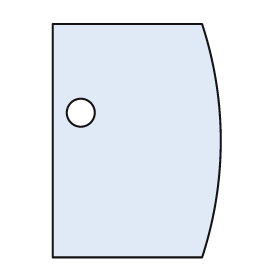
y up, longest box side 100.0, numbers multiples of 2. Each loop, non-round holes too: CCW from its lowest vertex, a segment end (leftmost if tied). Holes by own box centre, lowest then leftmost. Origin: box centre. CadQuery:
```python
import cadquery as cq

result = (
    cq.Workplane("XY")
    .moveTo(-36.0, -50.0)
    .lineTo(28.0, -50.0)
    .threePointArc((36.0, 0.0), (28.0, 50.0))
    .lineTo(-36.0, 50.0)
    .close()
    .moveTo(-24.0, 12.0)
    .circle(6.0)
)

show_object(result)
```